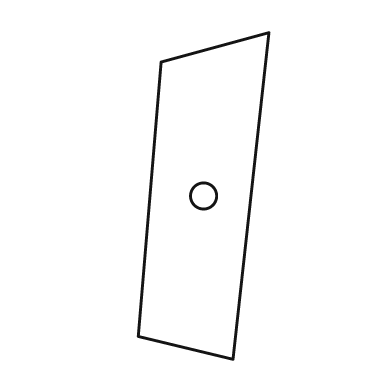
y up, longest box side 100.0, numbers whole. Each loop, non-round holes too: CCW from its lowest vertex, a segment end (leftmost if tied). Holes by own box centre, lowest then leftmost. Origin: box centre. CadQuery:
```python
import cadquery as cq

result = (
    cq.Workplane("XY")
    .moveTo(9.0, -50.0)
    .lineTo(20.0, 50.0)
    .lineTo(-13.0, 41.0)
    .lineTo(-20.0, -43.0)
    .close()
    .moveTo(0.0, 0.0)
    .circle(4.0)
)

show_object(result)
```